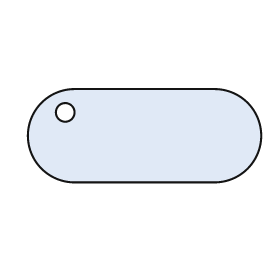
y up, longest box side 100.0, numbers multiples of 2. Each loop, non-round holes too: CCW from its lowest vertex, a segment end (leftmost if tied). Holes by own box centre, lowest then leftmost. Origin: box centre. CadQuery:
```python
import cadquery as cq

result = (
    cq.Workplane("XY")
    .moveTo(-30.0, -20.0)
    .lineTo(30.0, -20.0)
    .threePointArc((50.0, 0.0), (30.0, 20.0))
    .lineTo(-30.0, 20.0)
    .threePointArc((-50.0, 0.0), (-30.0, -20.0))
    .close()
    .moveTo(-34.0, 10.0)
    .circle(4.0)
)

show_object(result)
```